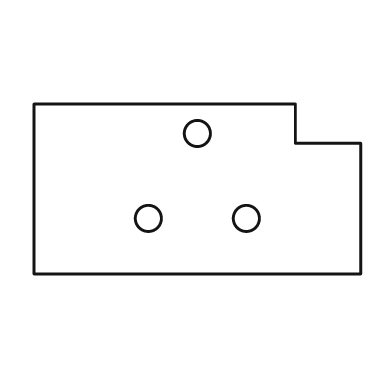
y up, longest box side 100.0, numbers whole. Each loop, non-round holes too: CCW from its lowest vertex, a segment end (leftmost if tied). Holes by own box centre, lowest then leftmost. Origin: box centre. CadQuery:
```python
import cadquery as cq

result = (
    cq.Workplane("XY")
    .moveTo(-50.0, -26.0)
    .lineTo(50.0, -26.0)
    .lineTo(50.0, 14.0)
    .lineTo(30.0, 14.0)
    .lineTo(30.0, 26.0)
    .lineTo(-50.0, 26.0)
    .close()
    .moveTo(-15.0, -9.0)
    .circle(4.0)
    .moveTo(15.0, -9.0)
    .circle(4.0)
    .moveTo(0.0, 17.0)
    .circle(4.0)
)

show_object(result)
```